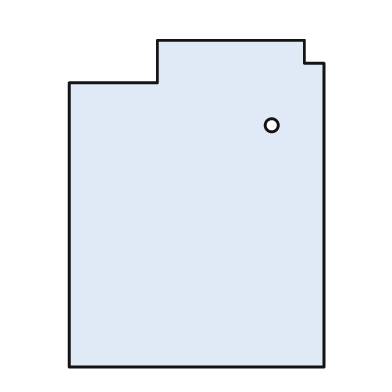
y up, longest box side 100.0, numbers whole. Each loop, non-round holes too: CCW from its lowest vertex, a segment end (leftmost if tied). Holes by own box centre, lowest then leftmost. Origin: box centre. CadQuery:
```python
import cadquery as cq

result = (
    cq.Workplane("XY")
    .moveTo(-39.0, -50.0)
    .lineTo(39.0, -50.0)
    .lineTo(39.0, 43.0)
    .lineTo(33.0, 43.0)
    .lineTo(33.0, 50.0)
    .lineTo(-12.0, 50.0)
    .lineTo(-12.0, 37.0)
    .lineTo(-39.0, 37.0)
    .close()
    .moveTo(23.0, 24.0)
    .circle(2.0)
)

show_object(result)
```